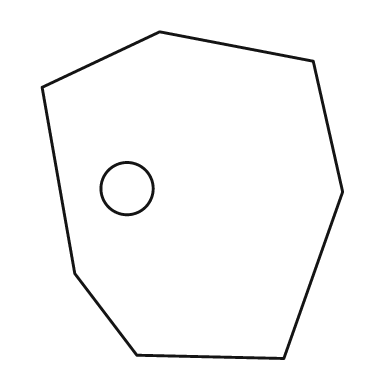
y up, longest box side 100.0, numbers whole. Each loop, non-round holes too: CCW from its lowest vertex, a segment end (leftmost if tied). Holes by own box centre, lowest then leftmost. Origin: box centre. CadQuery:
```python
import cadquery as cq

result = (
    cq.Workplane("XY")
    .moveTo(28.0, -50.0)
    .lineTo(46.0, 1.0)
    .lineTo(37.0, 41.0)
    .lineTo(-10.0, 50.0)
    .lineTo(-46.0, 33.0)
    .lineTo(-36.0, -24.0)
    .lineTo(-17.0, -49.0)
    .close()
    .moveTo(-20.0, 2.0)
    .circle(8.0)
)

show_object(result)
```